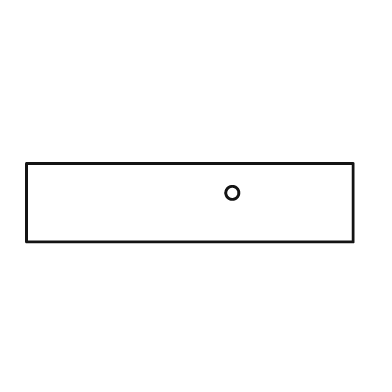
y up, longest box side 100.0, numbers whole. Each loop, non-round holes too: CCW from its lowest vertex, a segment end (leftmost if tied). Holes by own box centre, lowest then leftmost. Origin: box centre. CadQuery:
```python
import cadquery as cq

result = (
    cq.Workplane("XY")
    .moveTo(-50.0, -12.0)
    .lineTo(50.0, -12.0)
    .lineTo(50.0, 12.0)
    .lineTo(-50.0, 12.0)
    .close()
    .moveTo(13.0, 3.0)
    .circle(2.0)
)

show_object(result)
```